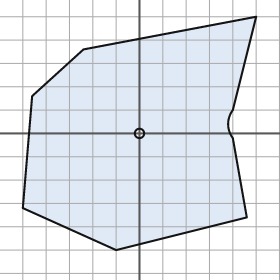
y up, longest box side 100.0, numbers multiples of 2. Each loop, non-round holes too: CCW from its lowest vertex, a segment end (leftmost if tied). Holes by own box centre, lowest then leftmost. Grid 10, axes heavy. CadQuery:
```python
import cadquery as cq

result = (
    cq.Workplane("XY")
    .moveTo(-10.0, -50.0)
    .lineTo(46.0, -36.0)
    .lineTo(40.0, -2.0)
    .threePointArc((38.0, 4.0), (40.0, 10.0))
    .lineTo(50.0, 50.0)
    .lineTo(-24.0, 36.0)
    .lineTo(-46.0, 16.0)
    .lineTo(-50.0, -32.0)
    .close()
    .moveTo(0.0, 0.0)
    .circle(2.0)
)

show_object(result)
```